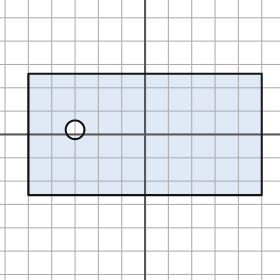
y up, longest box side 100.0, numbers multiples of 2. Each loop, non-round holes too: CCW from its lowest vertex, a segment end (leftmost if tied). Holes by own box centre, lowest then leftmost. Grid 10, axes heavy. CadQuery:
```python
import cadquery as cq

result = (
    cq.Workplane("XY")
    .moveTo(-50.0, -26.0)
    .lineTo(50.0, -26.0)
    .lineTo(50.0, 26.0)
    .lineTo(-50.0, 26.0)
    .close()
    .moveTo(-30.0, 2.0)
    .circle(4.0)
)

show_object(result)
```